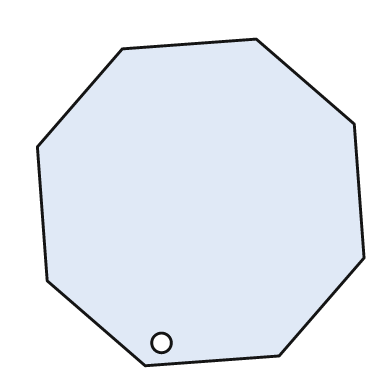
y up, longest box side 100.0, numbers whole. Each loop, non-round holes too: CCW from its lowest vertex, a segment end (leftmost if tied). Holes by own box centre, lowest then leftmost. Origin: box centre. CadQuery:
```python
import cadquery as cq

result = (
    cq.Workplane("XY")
    .moveTo(-17.0, -50.0)
    .lineTo(24.0, -47.0)
    .lineTo(50.0, -17.0)
    .lineTo(47.0, 24.0)
    .lineTo(17.0, 50.0)
    .lineTo(-24.0, 47.0)
    .lineTo(-50.0, 17.0)
    .lineTo(-47.0, -24.0)
    .close()
    .moveTo(-12.0, -43.0)
    .circle(3.0)
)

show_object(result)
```